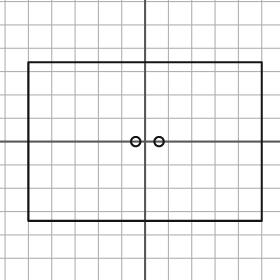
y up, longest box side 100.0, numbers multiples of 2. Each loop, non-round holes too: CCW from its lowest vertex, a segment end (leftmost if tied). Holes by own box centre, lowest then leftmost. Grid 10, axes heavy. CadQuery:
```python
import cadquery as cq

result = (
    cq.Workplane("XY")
    .moveTo(-50.0, -34.0)
    .lineTo(50.0, -34.0)
    .lineTo(50.0, 34.0)
    .lineTo(-50.0, 34.0)
    .close()
    .moveTo(-4.0, 0.0)
    .circle(2.0)
    .moveTo(6.0, 0.0)
    .circle(2.0)
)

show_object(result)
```